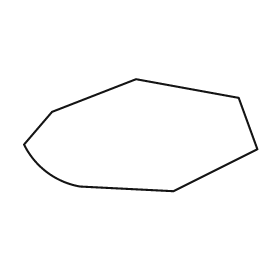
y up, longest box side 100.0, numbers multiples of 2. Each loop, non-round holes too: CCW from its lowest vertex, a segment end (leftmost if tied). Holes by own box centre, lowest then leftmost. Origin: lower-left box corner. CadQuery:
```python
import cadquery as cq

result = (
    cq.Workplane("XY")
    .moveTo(64.0, 0.0)
    .lineTo(100.0, 18.0)
    .lineTo(92.0, 40.0)
    .lineTo(48.0, 48.0)
    .lineTo(12.0, 34.0)
    .lineTo(0.0, 20.0)
    .threePointArc((10.0, 8.0), (24.0, 2.0))
    .close()
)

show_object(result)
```